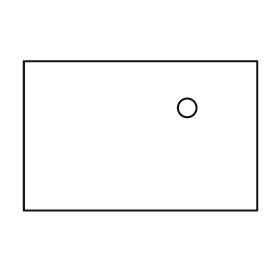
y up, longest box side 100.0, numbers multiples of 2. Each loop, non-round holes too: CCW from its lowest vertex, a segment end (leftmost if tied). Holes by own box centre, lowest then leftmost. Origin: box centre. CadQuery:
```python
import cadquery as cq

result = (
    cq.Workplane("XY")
    .moveTo(-50.0, -32.0)
    .lineTo(50.0, -32.0)
    .lineTo(50.0, 32.0)
    .lineTo(-50.0, 32.0)
    .close()
    .moveTo(20.0, 12.0)
    .circle(4.0)
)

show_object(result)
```